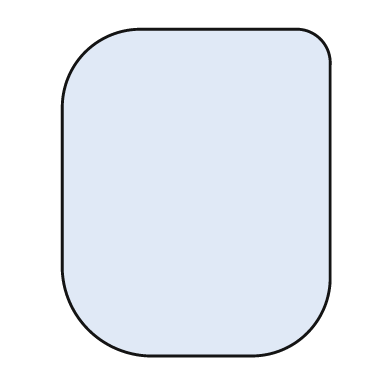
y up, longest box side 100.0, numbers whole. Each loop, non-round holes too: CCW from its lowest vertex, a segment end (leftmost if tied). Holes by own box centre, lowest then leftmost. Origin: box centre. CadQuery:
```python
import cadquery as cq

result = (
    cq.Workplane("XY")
    .moveTo(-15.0, -50.0)
    .lineTo(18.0, -50.0)
    .threePointArc((34.0, -43.0), (41.0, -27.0))
    .lineTo(41.0, 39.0)
    .threePointArc((38.0, 47.0), (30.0, 50.0))
    .lineTo(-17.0, 50.0)
    .threePointArc((-34.0, 43.0), (-41.0, 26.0))
    .lineTo(-41.0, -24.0)
    .threePointArc((-33.0, -42.0), (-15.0, -50.0))
    .close()
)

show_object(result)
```